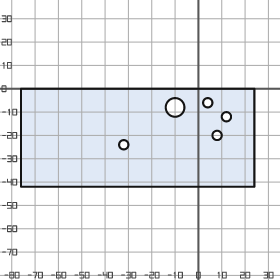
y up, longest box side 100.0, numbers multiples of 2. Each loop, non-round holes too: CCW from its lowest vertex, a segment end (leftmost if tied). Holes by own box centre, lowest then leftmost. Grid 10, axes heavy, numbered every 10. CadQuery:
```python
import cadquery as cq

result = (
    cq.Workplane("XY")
    .moveTo(-76.0, -42.0)
    .lineTo(24.0, -42.0)
    .lineTo(24.0, 0.0)
    .lineTo(-76.0, 0.0)
    .close()
    .moveTo(-32.0, -24.0)
    .circle(2.0)
    .moveTo(8.0, -20.0)
    .circle(2.0)
    .moveTo(12.0, -12.0)
    .circle(2.0)
    .moveTo(-10.0, -8.0)
    .circle(4.0)
    .moveTo(4.0, -6.0)
    .circle(2.0)
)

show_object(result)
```